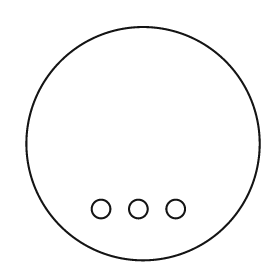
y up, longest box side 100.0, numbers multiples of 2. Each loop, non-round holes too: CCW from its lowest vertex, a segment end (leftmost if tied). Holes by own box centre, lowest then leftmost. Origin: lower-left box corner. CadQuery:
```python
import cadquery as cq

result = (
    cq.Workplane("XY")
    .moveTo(50.0, 50.0)
    .circle(50.0)
    .moveTo(32.0, 22.0)
    .circle(4.0)
    .moveTo(48.0, 22.0)
    .circle(4.0)
    .moveTo(64.0, 22.0)
    .circle(4.0)
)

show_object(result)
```